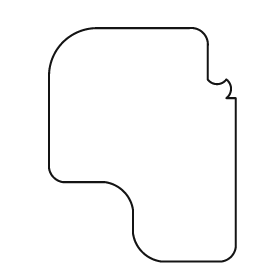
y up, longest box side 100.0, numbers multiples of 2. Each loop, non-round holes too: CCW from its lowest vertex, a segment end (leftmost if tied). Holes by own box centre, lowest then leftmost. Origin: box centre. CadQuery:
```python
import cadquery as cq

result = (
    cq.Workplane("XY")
    .moveTo(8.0, -50.0)
    .lineTo(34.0, -50.0)
    .threePointArc((38.0, -48.0), (40.0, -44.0))
    .lineTo(40.0, 20.0)
    .lineTo(36.0, 20.0)
    .threePointArc((38.0, 24.0), (36.0, 28.0))
    .threePointArc((32.0, 26.0), (28.0, 28.0))
    .lineTo(28.0, 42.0)
    .threePointArc((26.0, 48.0), (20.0, 50.0))
    .lineTo(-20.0, 50.0)
    .threePointArc((-34.0, 44.0), (-40.0, 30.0))
    .lineTo(-40.0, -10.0)
    .threePointArc((-38.0, -14.0), (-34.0, -16.0))
    .lineTo(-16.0, -16.0)
    .threePointArc((-8.0, -20.0), (-4.0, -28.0))
    .lineTo(-4.0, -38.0)
    .threePointArc((0.0, -46.0), (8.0, -50.0))
    .close()
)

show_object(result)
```